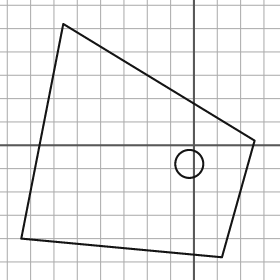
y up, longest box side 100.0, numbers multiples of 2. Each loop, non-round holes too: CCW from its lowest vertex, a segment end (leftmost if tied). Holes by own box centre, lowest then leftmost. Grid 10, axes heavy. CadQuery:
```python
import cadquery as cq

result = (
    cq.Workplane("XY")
    .moveTo(12.0, -48.0)
    .lineTo(26.0, 2.0)
    .lineTo(-56.0, 52.0)
    .lineTo(-74.0, -40.0)
    .close()
    .moveTo(-2.0, -8.0)
    .circle(6.0)
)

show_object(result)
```